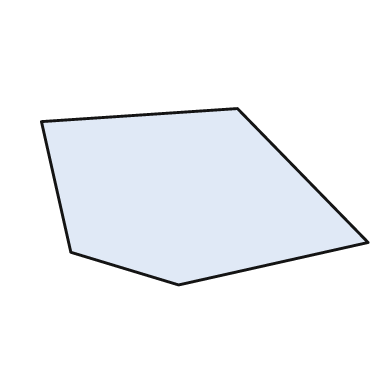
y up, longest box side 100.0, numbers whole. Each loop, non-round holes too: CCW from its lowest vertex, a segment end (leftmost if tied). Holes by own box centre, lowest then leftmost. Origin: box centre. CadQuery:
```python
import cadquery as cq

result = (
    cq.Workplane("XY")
    .moveTo(-8.0, -27.0)
    .lineTo(50.0, -14.0)
    .lineTo(10.0, 27.0)
    .lineTo(-50.0, 23.0)
    .lineTo(-41.0, -17.0)
    .close()
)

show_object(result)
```